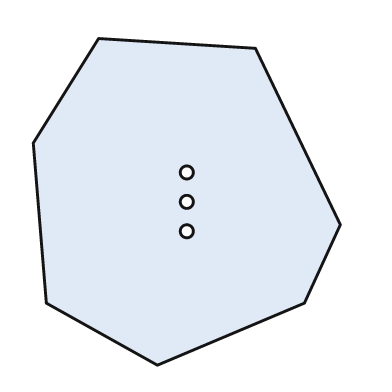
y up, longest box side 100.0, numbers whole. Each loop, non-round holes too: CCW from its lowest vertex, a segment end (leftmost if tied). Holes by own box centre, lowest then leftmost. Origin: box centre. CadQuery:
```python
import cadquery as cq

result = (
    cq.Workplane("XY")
    .moveTo(-9.0, -50.0)
    .lineTo(36.0, -31.0)
    .lineTo(47.0, -7.0)
    .lineTo(21.0, 47.0)
    .lineTo(-27.0, 50.0)
    .lineTo(-47.0, 18.0)
    .lineTo(-43.0, -31.0)
    .close()
    .moveTo(0.0, -9.0)
    .circle(2.0)
    .moveTo(0.0, 0.0)
    .circle(2.0)
    .moveTo(0.0, 9.0)
    .circle(2.0)
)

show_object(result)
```